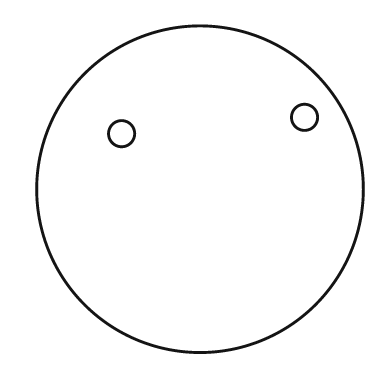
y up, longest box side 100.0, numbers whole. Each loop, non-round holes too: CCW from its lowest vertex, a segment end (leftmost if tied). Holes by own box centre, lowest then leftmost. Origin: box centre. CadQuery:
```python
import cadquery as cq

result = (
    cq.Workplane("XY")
    .moveTo(0.0, 0.0)
    .circle(50.0)
    .moveTo(-24.0, 17.0)
    .circle(4.0)
    .moveTo(32.0, 22.0)
    .circle(4.0)
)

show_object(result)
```